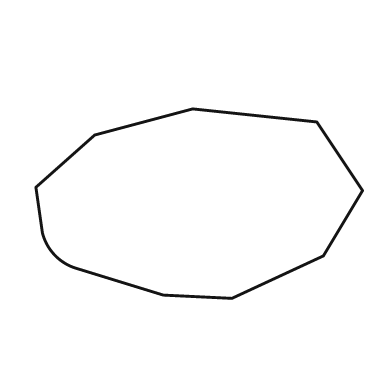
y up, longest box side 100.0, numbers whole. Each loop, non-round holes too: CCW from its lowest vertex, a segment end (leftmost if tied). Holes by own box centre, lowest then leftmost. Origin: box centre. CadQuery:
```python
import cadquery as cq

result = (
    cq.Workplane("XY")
    .moveTo(10.0, -29.0)
    .lineTo(38.0, -16.0)
    .lineTo(50.0, 4.0)
    .lineTo(36.0, 25.0)
    .lineTo(-2.0, 29.0)
    .lineTo(-32.0, 21.0)
    .lineTo(-50.0, 5.0)
    .lineTo(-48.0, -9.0)
    .threePointArc((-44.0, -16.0), (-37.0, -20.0))
    .lineTo(-11.0, -28.0)
    .close()
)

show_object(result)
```